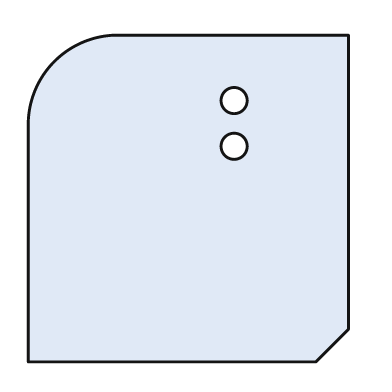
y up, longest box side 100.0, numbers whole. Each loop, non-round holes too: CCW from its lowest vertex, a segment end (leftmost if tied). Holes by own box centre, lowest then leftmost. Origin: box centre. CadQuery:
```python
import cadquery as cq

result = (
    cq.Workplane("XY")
    .moveTo(-49.0, -50.0)
    .lineTo(39.0, -50.0)
    .lineTo(49.0, -40.0)
    .lineTo(49.0, 50.0)
    .lineTo(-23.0, 50.0)
    .threePointArc((-41.0, 42.0), (-49.0, 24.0))
    .close()
    .moveTo(14.0, 16.0)
    .circle(4.0)
    .moveTo(14.0, 30.0)
    .circle(4.0)
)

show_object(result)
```